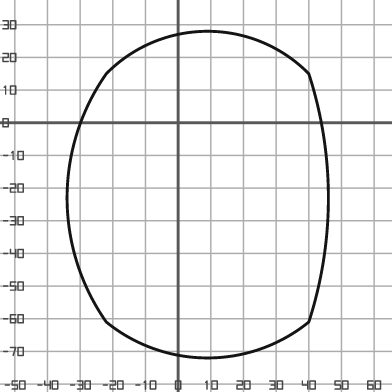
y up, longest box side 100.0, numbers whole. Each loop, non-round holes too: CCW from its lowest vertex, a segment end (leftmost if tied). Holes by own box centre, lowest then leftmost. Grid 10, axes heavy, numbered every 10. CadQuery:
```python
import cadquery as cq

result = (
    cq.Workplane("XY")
    .moveTo(-22.0, -61.0)
    .threePointArc((9.0, -72.0), (40.0, -61.0))
    .threePointArc((46.0, -23.0), (40.0, 15.0))
    .threePointArc((9.0, 28.0), (-22.0, 15.0))
    .threePointArc((-34.0, -23.0), (-22.0, -61.0))
    .close()
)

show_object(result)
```